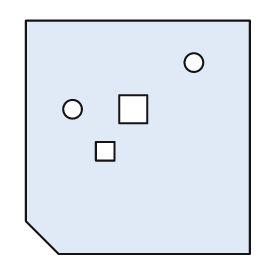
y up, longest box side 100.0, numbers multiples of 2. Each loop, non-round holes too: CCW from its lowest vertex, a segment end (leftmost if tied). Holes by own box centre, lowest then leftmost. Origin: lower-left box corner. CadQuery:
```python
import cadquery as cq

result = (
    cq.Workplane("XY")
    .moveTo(14.0, 0.0)
    .lineTo(96.0, 0.0)
    .lineTo(96.0, 100.0)
    .lineTo(0.0, 100.0)
    .lineTo(0.0, 14.0)
    .close()
    .moveTo(30.0, 40.0)
    .lineTo(38.0, 40.0)
    .lineTo(38.0, 48.0)
    .lineTo(30.0, 48.0)
    .close()
    .moveTo(20.0, 62.0)
    .circle(4.0)
    .moveTo(40.0, 56.0)
    .lineTo(52.0, 56.0)
    .lineTo(52.0, 68.0)
    .lineTo(40.0, 68.0)
    .close()
    .moveTo(72.0, 82.0)
    .circle(4.0)
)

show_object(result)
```